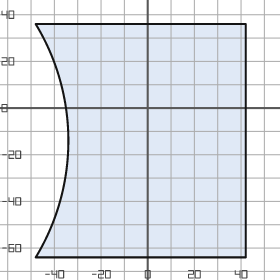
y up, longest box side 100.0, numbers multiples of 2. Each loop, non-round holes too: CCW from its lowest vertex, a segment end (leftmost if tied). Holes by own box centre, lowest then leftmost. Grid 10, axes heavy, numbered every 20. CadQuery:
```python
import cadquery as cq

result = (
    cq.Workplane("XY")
    .moveTo(-48.0, -64.0)
    .lineTo(42.0, -64.0)
    .lineTo(42.0, 36.0)
    .lineTo(-48.0, 36.0)
    .threePointArc((-34.0, -14.0), (-48.0, -64.0))
    .close()
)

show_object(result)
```